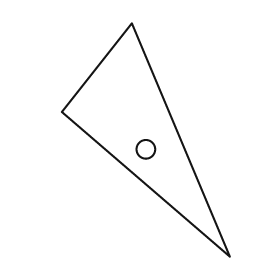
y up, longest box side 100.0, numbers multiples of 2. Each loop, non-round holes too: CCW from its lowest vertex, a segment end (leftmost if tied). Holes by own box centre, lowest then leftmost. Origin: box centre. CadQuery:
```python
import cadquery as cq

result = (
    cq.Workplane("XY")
    .moveTo(36.0, -50.0)
    .lineTo(-6.0, 50.0)
    .lineTo(-36.0, 12.0)
    .close()
    .moveTo(0.0, -4.0)
    .circle(4.0)
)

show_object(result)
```